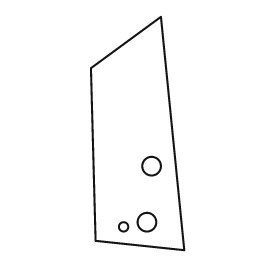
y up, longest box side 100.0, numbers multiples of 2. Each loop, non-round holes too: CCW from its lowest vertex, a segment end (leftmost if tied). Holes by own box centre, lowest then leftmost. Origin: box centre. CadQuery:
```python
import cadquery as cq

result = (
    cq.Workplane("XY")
    .moveTo(20.0, -50.0)
    .lineTo(10.0, 50.0)
    .lineTo(-20.0, 28.0)
    .lineTo(-18.0, -46.0)
    .close()
    .moveTo(-6.0, -40.0)
    .circle(2.0)
    .moveTo(4.0, -38.0)
    .circle(4.0)
    .moveTo(6.0, -14.0)
    .circle(4.0)
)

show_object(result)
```